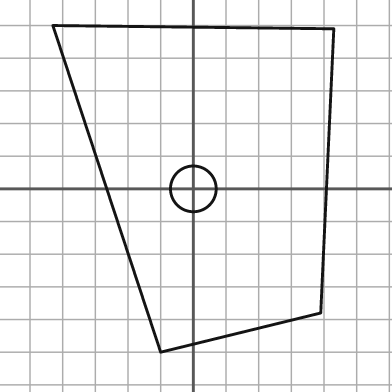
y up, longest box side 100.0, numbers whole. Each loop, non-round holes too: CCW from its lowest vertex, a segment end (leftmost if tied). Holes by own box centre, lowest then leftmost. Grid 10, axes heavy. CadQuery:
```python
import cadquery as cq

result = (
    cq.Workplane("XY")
    .moveTo(-10.0, -50.0)
    .lineTo(39.0, -38.0)
    .lineTo(43.0, 49.0)
    .lineTo(-43.0, 50.0)
    .close()
    .moveTo(0.0, 0.0)
    .circle(7.0)
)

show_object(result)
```